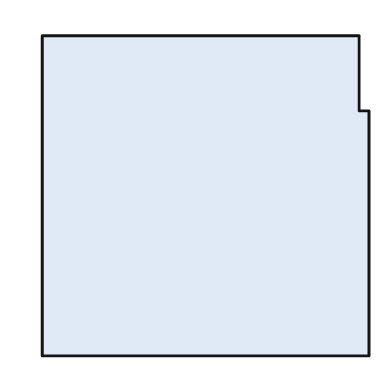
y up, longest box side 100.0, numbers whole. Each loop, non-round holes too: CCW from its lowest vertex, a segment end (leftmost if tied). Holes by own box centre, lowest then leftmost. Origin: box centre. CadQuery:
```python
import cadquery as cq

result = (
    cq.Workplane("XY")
    .moveTo(-50.0, -49.0)
    .lineTo(50.0, -49.0)
    .lineTo(50.0, 26.0)
    .lineTo(47.0, 26.0)
    .lineTo(47.0, 49.0)
    .lineTo(-50.0, 49.0)
    .close()
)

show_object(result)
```